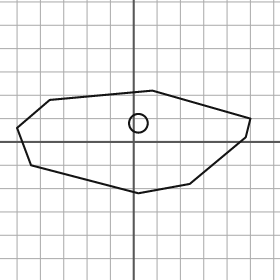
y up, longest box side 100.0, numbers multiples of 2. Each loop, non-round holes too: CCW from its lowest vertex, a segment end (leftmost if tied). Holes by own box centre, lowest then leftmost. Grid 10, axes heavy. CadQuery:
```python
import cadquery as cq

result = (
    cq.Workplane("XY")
    .moveTo(2.0, -22.0)
    .lineTo(24.0, -18.0)
    .lineTo(48.0, 2.0)
    .lineTo(50.0, 10.0)
    .lineTo(8.0, 22.0)
    .lineTo(-36.0, 18.0)
    .lineTo(-50.0, 6.0)
    .lineTo(-44.0, -10.0)
    .close()
    .moveTo(2.0, 8.0)
    .circle(4.0)
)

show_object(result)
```